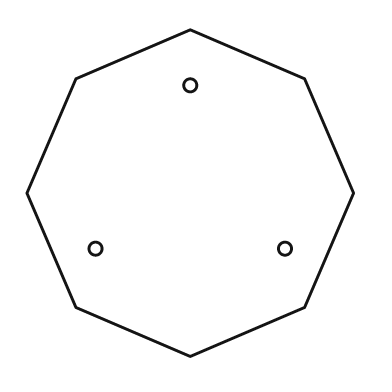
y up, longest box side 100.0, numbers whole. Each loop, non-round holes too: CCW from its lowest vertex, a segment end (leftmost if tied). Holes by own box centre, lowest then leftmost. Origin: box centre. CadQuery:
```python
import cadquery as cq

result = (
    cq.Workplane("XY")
    .moveTo(0.0, -50.0)
    .lineTo(35.0, -35.0)
    .lineTo(50.0, 0.0)
    .lineTo(35.0, 35.0)
    .lineTo(0.0, 50.0)
    .lineTo(-35.0, 35.0)
    .lineTo(-50.0, 0.0)
    .lineTo(-35.0, -35.0)
    .close()
    .moveTo(-29.0, -17.0)
    .circle(2.0)
    .moveTo(29.0, -17.0)
    .circle(2.0)
    .moveTo(0.0, 33.0)
    .circle(2.0)
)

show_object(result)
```